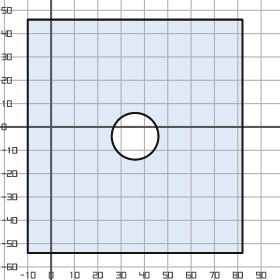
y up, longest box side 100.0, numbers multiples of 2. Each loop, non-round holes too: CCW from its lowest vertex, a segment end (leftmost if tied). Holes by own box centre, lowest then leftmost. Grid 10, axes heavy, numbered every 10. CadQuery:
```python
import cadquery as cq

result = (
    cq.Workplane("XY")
    .moveTo(-10.0, -54.0)
    .lineTo(82.0, -54.0)
    .lineTo(82.0, 46.0)
    .lineTo(-10.0, 46.0)
    .close()
    .moveTo(36.0, -4.0)
    .circle(10.0)
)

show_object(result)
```